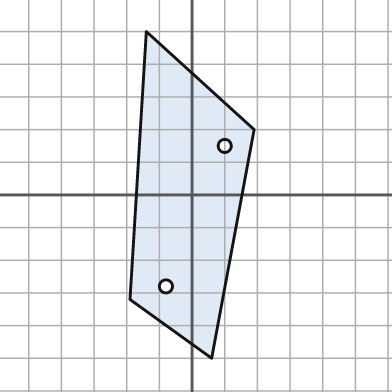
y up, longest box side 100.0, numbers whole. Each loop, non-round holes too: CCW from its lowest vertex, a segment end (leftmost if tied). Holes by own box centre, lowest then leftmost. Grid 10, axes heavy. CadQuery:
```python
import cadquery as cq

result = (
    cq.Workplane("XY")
    .moveTo(6.0, -50.0)
    .lineTo(19.0, 20.0)
    .lineTo(-14.0, 50.0)
    .lineTo(-19.0, -32.0)
    .close()
    .moveTo(-8.0, -28.0)
    .circle(2.0)
    .moveTo(10.0, 15.0)
    .circle(2.0)
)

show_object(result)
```